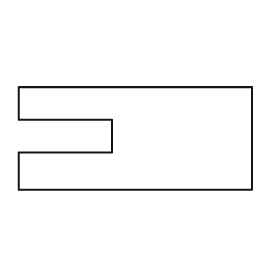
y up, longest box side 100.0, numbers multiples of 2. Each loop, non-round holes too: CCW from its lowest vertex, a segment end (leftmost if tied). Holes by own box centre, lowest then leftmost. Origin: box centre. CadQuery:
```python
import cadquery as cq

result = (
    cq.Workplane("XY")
    .moveTo(-50.0, -22.0)
    .lineTo(50.0, -22.0)
    .lineTo(50.0, 22.0)
    .lineTo(-50.0, 22.0)
    .lineTo(-50.0, 8.0)
    .lineTo(-10.0, 8.0)
    .lineTo(-10.0, -6.0)
    .lineTo(-50.0, -6.0)
    .close()
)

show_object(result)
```